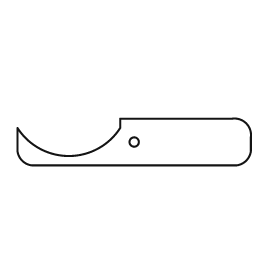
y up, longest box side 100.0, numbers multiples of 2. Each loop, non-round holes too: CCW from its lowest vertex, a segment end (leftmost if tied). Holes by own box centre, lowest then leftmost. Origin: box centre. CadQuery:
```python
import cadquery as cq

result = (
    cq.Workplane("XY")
    .moveTo(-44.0, -10.0)
    .lineTo(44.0, -10.0)
    .threePointArc((48.0, -8.0), (50.0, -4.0))
    .lineTo(50.0, 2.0)
    .threePointArc((48.0, 8.0), (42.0, 10.0))
    .lineTo(-6.0, 10.0)
    .lineTo(-6.0, 6.0)
    .threePointArc((-28.0, -6.0), (-50.0, 6.0))
    .lineTo(-50.0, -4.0)
    .threePointArc((-48.0, -8.0), (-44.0, -10.0))
    .close()
    .moveTo(0.0, 0.0)
    .circle(2.0)
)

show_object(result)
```